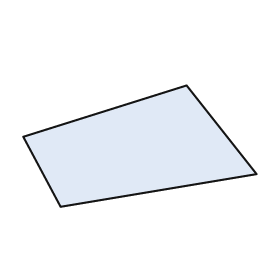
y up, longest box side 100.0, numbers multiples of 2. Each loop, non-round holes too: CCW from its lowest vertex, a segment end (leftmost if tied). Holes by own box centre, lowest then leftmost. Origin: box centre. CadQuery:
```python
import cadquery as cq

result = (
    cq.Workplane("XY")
    .moveTo(-34.0, -26.0)
    .lineTo(50.0, -12.0)
    .lineTo(20.0, 26.0)
    .lineTo(-50.0, 4.0)
    .close()
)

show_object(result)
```